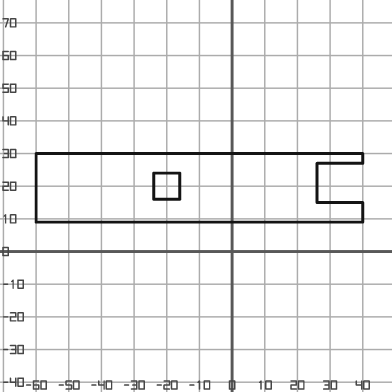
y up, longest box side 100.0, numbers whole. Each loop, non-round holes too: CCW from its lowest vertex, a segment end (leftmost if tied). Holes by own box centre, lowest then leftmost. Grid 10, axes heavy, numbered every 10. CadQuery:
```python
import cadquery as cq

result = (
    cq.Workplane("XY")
    .moveTo(-60.0, 9.0)
    .lineTo(40.0, 9.0)
    .lineTo(40.0, 15.0)
    .lineTo(26.0, 15.0)
    .lineTo(26.0, 27.0)
    .lineTo(40.0, 27.0)
    .lineTo(40.0, 30.0)
    .lineTo(-60.0, 30.0)
    .close()
    .moveTo(-24.0, 16.0)
    .lineTo(-16.0, 16.0)
    .lineTo(-16.0, 24.0)
    .lineTo(-24.0, 24.0)
    .close()
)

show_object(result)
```